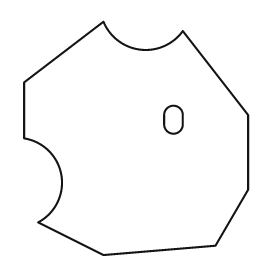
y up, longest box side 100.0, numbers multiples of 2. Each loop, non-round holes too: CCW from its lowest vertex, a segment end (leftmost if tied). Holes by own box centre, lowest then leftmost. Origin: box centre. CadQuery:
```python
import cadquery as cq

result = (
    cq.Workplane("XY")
    .moveTo(-14.0, -50.0)
    .lineTo(34.0, -46.0)
    .lineTo(48.0, -22.0)
    .lineTo(48.0, 10.0)
    .lineTo(20.0, 46.0)
    .threePointArc((2.0, 38.0), (-14.0, 50.0))
    .lineTo(-48.0, 24.0)
    .lineTo(-48.0, 0.0)
    .threePointArc((-32.0, -16.0), (-42.0, -36.0))
    .close()
    .moveTo(12.0, 6.0)
    .threePointArc((16.0, 2.0), (20.0, 6.0))
    .lineTo(20.0, 10.0)
    .threePointArc((16.0, 14.0), (12.0, 10.0))
    .close()
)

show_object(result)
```